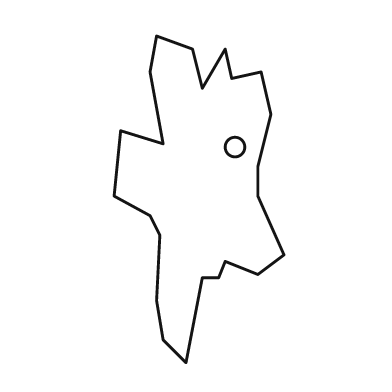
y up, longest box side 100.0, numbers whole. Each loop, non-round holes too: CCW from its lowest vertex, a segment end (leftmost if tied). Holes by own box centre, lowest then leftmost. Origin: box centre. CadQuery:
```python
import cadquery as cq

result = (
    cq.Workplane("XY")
    .moveTo(-4.0, -50.0)
    .lineTo(1.0, -24.0)
    .lineTo(6.0, -24.0)
    .lineTo(8.0, -19.0)
    .lineTo(18.0, -23.0)
    .lineTo(26.0, -17.0)
    .lineTo(18.0, 1.0)
    .lineTo(18.0, 10.0)
    .lineTo(22.0, 26.0)
    .lineTo(19.0, 39.0)
    .lineTo(10.0, 37.0)
    .lineTo(8.0, 46.0)
    .lineTo(1.0, 34.0)
    .lineTo(-2.0, 46.0)
    .lineTo(-13.0, 50.0)
    .lineTo(-15.0, 39.0)
    .lineTo(-11.0, 17.0)
    .lineTo(-24.0, 21.0)
    .lineTo(-26.0, 1.0)
    .lineTo(-15.0, -5.0)
    .lineTo(-12.0, -11.0)
    .lineTo(-13.0, -31.0)
    .lineTo(-11.0, -43.0)
    .close()
    .moveTo(11.0, 16.0)
    .circle(3.0)
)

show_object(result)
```